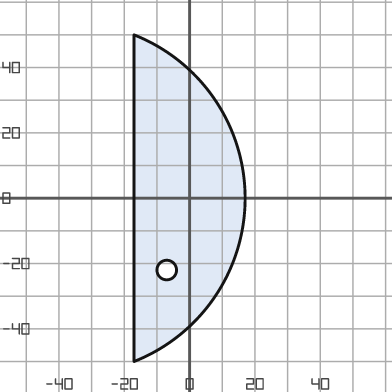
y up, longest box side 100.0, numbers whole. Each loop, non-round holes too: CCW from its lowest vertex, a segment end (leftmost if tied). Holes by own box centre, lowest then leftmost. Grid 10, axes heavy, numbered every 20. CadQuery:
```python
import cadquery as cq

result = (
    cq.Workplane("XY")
    .moveTo(-17.0, -50.0)
    .threePointArc((17.0, 0.0), (-17.0, 50.0))
    .close()
    .moveTo(-7.0, -22.0)
    .circle(3.0)
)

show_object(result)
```